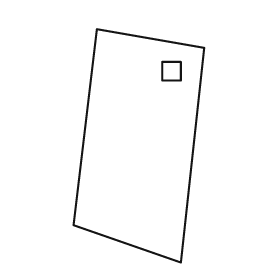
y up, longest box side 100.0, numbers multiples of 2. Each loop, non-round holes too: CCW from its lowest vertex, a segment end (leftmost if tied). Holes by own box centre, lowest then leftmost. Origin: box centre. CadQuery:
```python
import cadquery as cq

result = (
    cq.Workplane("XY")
    .moveTo(18.0, -50.0)
    .lineTo(28.0, 42.0)
    .lineTo(-18.0, 50.0)
    .lineTo(-28.0, -34.0)
    .close()
    .moveTo(10.0, 28.0)
    .lineTo(18.0, 28.0)
    .lineTo(18.0, 36.0)
    .lineTo(10.0, 36.0)
    .close()
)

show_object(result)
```